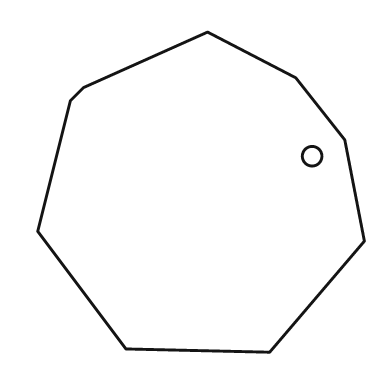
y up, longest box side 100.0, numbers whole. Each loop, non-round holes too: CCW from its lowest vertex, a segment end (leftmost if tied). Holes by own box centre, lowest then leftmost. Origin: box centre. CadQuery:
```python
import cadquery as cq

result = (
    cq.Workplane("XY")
    .moveTo(21.0, -49.0)
    .lineTo(50.0, -15.0)
    .lineTo(44.0, 16.0)
    .lineTo(29.0, 35.0)
    .lineTo(2.0, 49.0)
    .lineTo(-36.0, 32.0)
    .lineTo(-40.0, 28.0)
    .lineTo(-50.0, -12.0)
    .lineTo(-23.0, -48.0)
    .close()
    .moveTo(34.0, 11.0)
    .circle(3.0)
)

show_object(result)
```